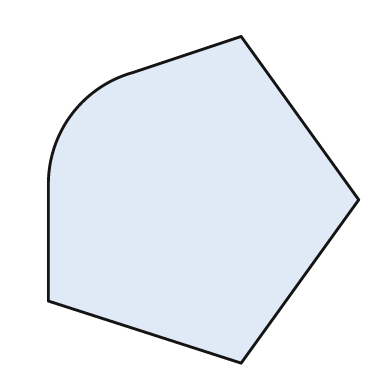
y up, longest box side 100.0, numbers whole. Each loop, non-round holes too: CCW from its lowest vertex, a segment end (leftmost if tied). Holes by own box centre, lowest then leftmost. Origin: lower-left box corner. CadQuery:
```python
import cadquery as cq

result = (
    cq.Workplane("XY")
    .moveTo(59.0, 0.0)
    .lineTo(95.0, 50.0)
    .lineTo(59.0, 100.0)
    .lineTo(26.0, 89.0)
    .threePointArc((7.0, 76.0), (0.0, 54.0))
    .lineTo(0.0, 19.0)
    .close()
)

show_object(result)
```